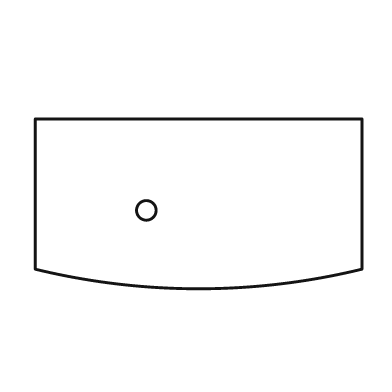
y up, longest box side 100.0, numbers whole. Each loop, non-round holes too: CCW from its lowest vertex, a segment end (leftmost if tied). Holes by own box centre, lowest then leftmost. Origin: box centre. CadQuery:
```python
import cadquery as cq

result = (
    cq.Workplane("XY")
    .moveTo(-50.0, -20.0)
    .threePointArc((0.0, -26.0), (50.0, -20.0))
    .lineTo(50.0, 26.0)
    .lineTo(-50.0, 26.0)
    .close()
    .moveTo(-16.0, -2.0)
    .circle(3.0)
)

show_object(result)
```